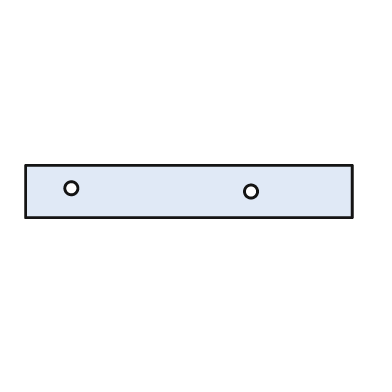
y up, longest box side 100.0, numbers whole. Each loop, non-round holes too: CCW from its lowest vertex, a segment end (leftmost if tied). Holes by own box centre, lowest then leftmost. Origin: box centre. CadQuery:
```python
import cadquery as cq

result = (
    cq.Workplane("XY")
    .moveTo(-50.0, -8.0)
    .lineTo(50.0, -8.0)
    .lineTo(50.0, 8.0)
    .lineTo(-50.0, 8.0)
    .close()
    .moveTo(19.0, 0.0)
    .circle(2.0)
    .moveTo(-36.0, 1.0)
    .circle(2.0)
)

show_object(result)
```